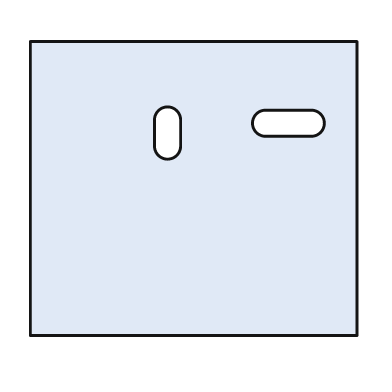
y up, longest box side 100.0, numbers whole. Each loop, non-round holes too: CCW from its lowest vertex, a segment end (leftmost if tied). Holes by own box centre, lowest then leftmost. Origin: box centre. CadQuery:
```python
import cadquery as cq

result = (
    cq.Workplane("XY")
    .moveTo(-50.0, -45.0)
    .lineTo(50.0, -45.0)
    .lineTo(50.0, 45.0)
    .lineTo(-50.0, 45.0)
    .close()
    .moveTo(-12.0, 13.0)
    .threePointArc((-8.0, 9.0), (-4.0, 13.0))
    .lineTo(-4.0, 21.0)
    .threePointArc((-8.0, 25.0), (-12.0, 21.0))
    .close()
    .moveTo(22.0, 16.0)
    .lineTo(36.0, 16.0)
    .threePointArc((40.0, 20.0), (36.0, 24.0))
    .lineTo(22.0, 24.0)
    .threePointArc((18.0, 20.0), (22.0, 16.0))
    .close()
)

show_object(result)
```